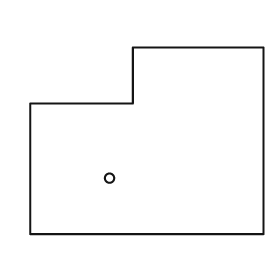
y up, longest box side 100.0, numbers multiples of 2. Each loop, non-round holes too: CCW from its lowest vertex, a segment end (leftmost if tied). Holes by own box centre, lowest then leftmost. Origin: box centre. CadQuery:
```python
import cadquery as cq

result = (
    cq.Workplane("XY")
    .moveTo(-50.0, -40.0)
    .lineTo(50.0, -40.0)
    .lineTo(50.0, 40.0)
    .lineTo(-6.0, 40.0)
    .lineTo(-6.0, 16.0)
    .lineTo(-50.0, 16.0)
    .close()
    .moveTo(-16.0, -16.0)
    .circle(2.0)
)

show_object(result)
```